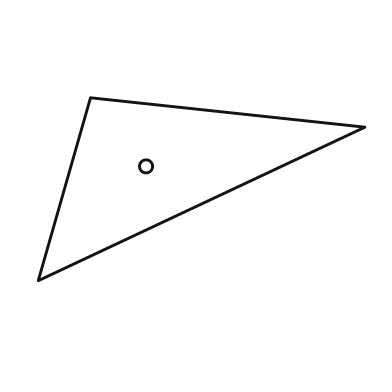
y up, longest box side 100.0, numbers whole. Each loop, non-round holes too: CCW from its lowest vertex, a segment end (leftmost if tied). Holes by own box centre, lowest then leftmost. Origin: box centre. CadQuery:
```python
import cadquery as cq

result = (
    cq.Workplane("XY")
    .moveTo(-50.0, -28.0)
    .lineTo(50.0, 19.0)
    .lineTo(-34.0, 28.0)
    .close()
    .moveTo(-17.0, 7.0)
    .circle(2.0)
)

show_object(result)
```